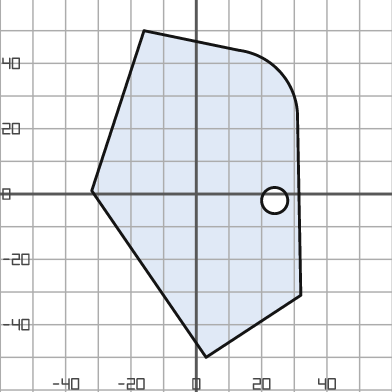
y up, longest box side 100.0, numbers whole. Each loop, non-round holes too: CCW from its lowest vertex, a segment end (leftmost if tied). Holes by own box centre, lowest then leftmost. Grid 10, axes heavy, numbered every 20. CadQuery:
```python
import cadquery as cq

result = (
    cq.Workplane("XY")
    .moveTo(3.0, -50.0)
    .lineTo(32.0, -31.0)
    .lineTo(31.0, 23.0)
    .threePointArc((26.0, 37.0), (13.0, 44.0))
    .lineTo(-16.0, 50.0)
    .lineTo(-32.0, 1.0)
    .close()
    .moveTo(24.0, -2.0)
    .circle(4.0)
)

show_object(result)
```